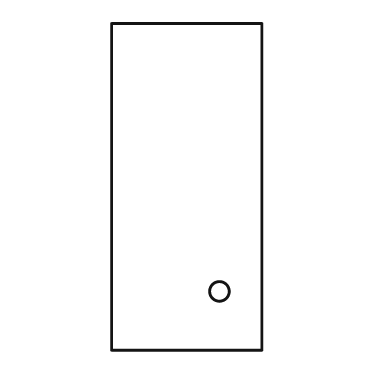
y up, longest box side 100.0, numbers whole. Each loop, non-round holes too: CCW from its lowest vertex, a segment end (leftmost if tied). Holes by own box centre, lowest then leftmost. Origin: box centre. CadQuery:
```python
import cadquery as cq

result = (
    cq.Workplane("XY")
    .moveTo(-23.0, -50.0)
    .lineTo(23.0, -50.0)
    .lineTo(23.0, 50.0)
    .lineTo(-23.0, 50.0)
    .close()
    .moveTo(10.0, -32.0)
    .circle(3.0)
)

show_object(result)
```